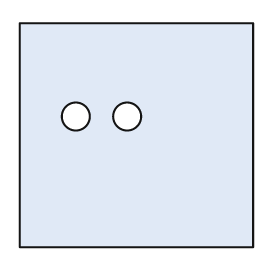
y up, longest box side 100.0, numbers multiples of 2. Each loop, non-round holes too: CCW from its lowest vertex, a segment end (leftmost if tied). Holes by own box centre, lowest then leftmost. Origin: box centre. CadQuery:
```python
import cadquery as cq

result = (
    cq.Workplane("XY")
    .moveTo(-50.0, -48.0)
    .lineTo(50.0, -48.0)
    .lineTo(50.0, 48.0)
    .lineTo(-50.0, 48.0)
    .close()
    .moveTo(-26.0, 8.0)
    .circle(6.0)
    .moveTo(-4.0, 8.0)
    .circle(6.0)
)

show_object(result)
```